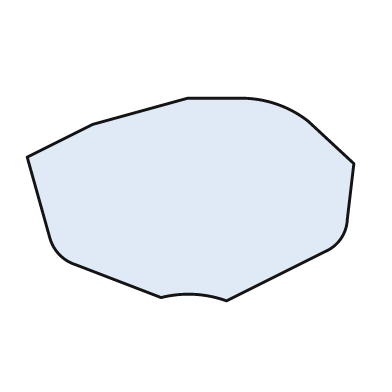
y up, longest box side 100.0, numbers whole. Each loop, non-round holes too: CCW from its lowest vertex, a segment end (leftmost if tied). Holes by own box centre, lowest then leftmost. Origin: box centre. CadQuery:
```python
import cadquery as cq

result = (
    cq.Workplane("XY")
    .moveTo(11.0, -31.0)
    .lineTo(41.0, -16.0)
    .threePointArc((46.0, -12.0), (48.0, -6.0))
    .lineTo(50.0, 11.0)
    .lineTo(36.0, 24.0)
    .threePointArc((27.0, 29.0), (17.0, 31.0))
    .lineTo(-1.0, 31.0)
    .lineTo(-30.0, 23.0)
    .lineTo(-50.0, 13.0)
    .lineTo(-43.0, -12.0)
    .threePointArc((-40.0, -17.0), (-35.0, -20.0))
    .lineTo(-9.0, -30.0)
    .threePointArc((1.0, -29.0), (11.0, -31.0))
    .close()
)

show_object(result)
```